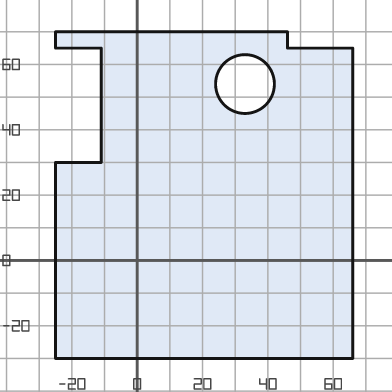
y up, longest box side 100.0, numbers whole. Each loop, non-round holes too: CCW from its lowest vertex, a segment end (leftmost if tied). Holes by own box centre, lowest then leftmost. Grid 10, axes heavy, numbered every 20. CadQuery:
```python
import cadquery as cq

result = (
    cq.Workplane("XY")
    .moveTo(-25.0, -30.0)
    .lineTo(66.0, -30.0)
    .lineTo(66.0, 65.0)
    .lineTo(46.0, 65.0)
    .lineTo(46.0, 70.0)
    .lineTo(-25.0, 70.0)
    .lineTo(-25.0, 65.0)
    .lineTo(-11.0, 65.0)
    .lineTo(-11.0, 30.0)
    .lineTo(-25.0, 30.0)
    .close()
    .moveTo(33.0, 54.0)
    .circle(9.0)
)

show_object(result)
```